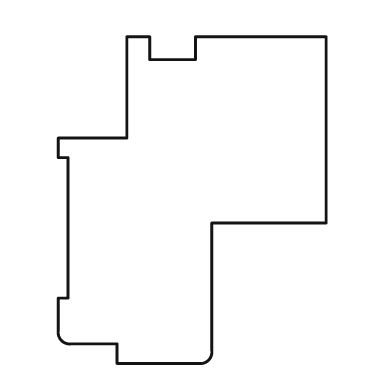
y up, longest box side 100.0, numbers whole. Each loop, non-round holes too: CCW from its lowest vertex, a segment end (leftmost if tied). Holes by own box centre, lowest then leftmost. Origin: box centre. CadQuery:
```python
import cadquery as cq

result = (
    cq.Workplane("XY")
    .moveTo(-23.0, -50.0)
    .lineTo(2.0, -50.0)
    .threePointArc((5.0, -49.0), (6.0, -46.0))
    .lineTo(6.0, -7.0)
    .lineTo(41.0, -7.0)
    .lineTo(41.0, 50.0)
    .lineTo(1.0, 50.0)
    .lineTo(1.0, 43.0)
    .lineTo(-13.0, 43.0)
    .lineTo(-13.0, 50.0)
    .lineTo(-20.0, 50.0)
    .lineTo(-20.0, 19.0)
    .lineTo(-41.0, 19.0)
    .lineTo(-41.0, 13.0)
    .lineTo(-38.0, 13.0)
    .lineTo(-38.0, -30.0)
    .lineTo(-41.0, -30.0)
    .lineTo(-41.0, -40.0)
    .threePointArc((-40.0, -43.0), (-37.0, -44.0))
    .lineTo(-23.0, -44.0)
    .close()
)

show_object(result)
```